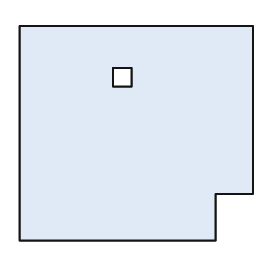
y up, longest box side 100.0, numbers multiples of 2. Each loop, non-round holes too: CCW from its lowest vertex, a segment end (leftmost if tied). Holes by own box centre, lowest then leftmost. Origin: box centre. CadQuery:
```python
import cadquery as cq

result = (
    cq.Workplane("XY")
    .moveTo(-50.0, -46.0)
    .lineTo(34.0, -46.0)
    .lineTo(34.0, -26.0)
    .lineTo(50.0, -26.0)
    .lineTo(50.0, 46.0)
    .lineTo(-50.0, 46.0)
    .close()
    .moveTo(-10.0, 20.0)
    .lineTo(-2.0, 20.0)
    .lineTo(-2.0, 28.0)
    .lineTo(-10.0, 28.0)
    .close()
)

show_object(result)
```